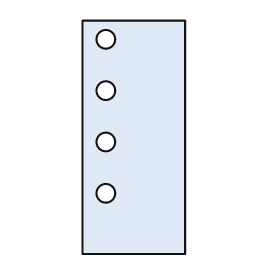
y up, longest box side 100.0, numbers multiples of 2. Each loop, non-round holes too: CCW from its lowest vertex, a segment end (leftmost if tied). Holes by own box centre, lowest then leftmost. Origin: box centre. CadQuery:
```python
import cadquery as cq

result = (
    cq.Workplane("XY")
    .moveTo(-22.0, -50.0)
    .lineTo(22.0, -50.0)
    .lineTo(22.0, 50.0)
    .lineTo(-22.0, 50.0)
    .close()
    .moveTo(-12.0, -24.0)
    .circle(4.0)
    .moveTo(-12.0, -2.0)
    .circle(4.0)
    .moveTo(-12.0, 20.0)
    .circle(4.0)
    .moveTo(-12.0, 42.0)
    .circle(4.0)
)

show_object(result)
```